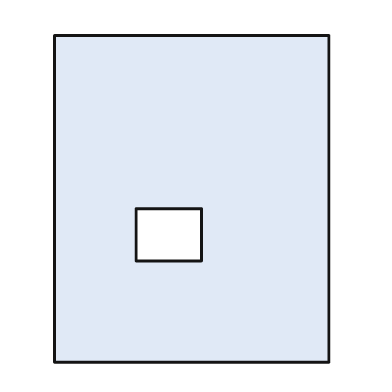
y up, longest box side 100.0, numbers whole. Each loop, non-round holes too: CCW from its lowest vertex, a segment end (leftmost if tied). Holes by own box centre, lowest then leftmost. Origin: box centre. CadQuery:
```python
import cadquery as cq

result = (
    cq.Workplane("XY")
    .moveTo(-42.0, -50.0)
    .lineTo(42.0, -50.0)
    .lineTo(42.0, 50.0)
    .lineTo(-42.0, 50.0)
    .close()
    .moveTo(-17.0, -19.0)
    .lineTo(3.0, -19.0)
    .lineTo(3.0, -3.0)
    .lineTo(-17.0, -3.0)
    .close()
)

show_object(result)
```